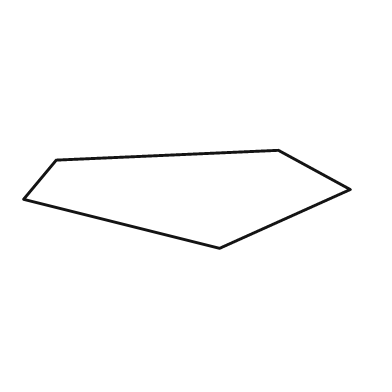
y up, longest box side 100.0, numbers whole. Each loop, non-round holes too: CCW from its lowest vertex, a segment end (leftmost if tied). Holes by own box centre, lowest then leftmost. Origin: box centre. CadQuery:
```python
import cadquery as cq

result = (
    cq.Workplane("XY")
    .moveTo(10.0, -15.0)
    .lineTo(50.0, 3.0)
    .lineTo(28.0, 15.0)
    .lineTo(-40.0, 12.0)
    .lineTo(-50.0, 0.0)
    .close()
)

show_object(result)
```